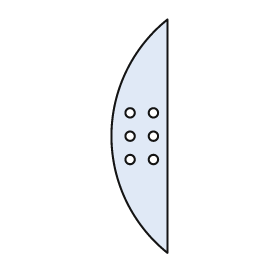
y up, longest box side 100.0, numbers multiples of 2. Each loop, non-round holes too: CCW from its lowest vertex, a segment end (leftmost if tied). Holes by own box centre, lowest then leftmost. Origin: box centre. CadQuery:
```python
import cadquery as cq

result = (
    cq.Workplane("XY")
    .moveTo(12.0, -50.0)
    .lineTo(12.0, 50.0)
    .threePointArc((-12.0, 0.0), (12.0, -50.0))
    .close()
    .moveTo(-4.0, -10.0)
    .circle(2.0)
    .moveTo(6.0, -10.0)
    .circle(2.0)
    .moveTo(-4.0, 0.0)
    .circle(2.0)
    .moveTo(6.0, 0.0)
    .circle(2.0)
    .moveTo(-4.0, 10.0)
    .circle(2.0)
    .moveTo(6.0, 10.0)
    .circle(2.0)
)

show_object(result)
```